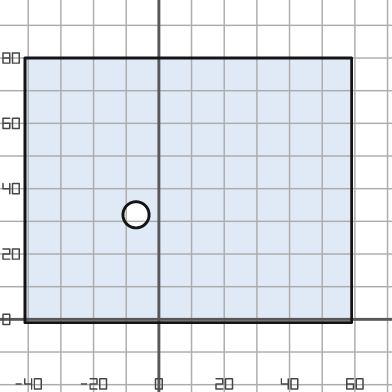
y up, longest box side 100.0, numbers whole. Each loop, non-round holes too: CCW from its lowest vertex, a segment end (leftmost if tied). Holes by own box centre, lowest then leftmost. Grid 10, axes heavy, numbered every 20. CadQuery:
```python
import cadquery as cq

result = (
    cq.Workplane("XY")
    .moveTo(-41.0, -1.0)
    .lineTo(59.0, -1.0)
    .lineTo(59.0, 80.0)
    .lineTo(-41.0, 80.0)
    .close()
    .moveTo(-7.0, 32.0)
    .circle(4.0)
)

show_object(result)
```